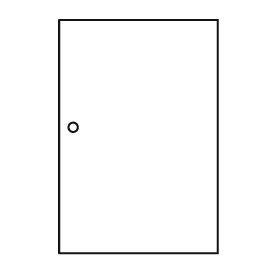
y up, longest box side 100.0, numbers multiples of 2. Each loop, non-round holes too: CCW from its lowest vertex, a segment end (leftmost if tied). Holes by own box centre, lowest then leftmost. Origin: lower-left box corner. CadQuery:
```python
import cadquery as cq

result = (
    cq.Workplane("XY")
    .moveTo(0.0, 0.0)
    .lineTo(68.0, 0.0)
    .lineTo(68.0, 100.0)
    .lineTo(0.0, 100.0)
    .close()
    .moveTo(6.0, 54.0)
    .circle(2.0)
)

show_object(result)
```